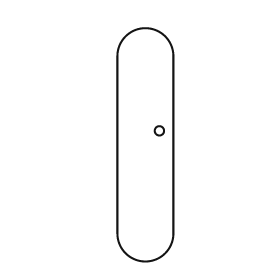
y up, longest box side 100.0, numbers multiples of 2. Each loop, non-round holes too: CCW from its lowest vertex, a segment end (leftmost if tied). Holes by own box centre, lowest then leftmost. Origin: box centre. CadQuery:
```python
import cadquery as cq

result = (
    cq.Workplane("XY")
    .moveTo(-12.0, -38.0)
    .threePointArc((0.0, -50.0), (12.0, -38.0))
    .lineTo(12.0, 38.0)
    .threePointArc((0.0, 50.0), (-12.0, 38.0))
    .close()
    .moveTo(6.0, 6.0)
    .circle(2.0)
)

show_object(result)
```